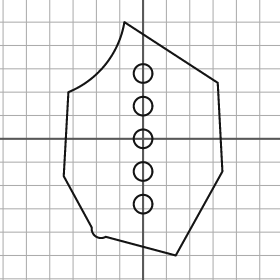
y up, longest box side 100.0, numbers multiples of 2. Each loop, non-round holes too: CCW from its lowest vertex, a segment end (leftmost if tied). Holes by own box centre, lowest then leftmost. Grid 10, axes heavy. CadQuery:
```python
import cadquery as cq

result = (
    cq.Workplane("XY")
    .moveTo(14.0, -50.0)
    .lineTo(34.0, -14.0)
    .lineTo(32.0, 24.0)
    .lineTo(-8.0, 50.0)
    .threePointArc((-16.0, 32.0), (-32.0, 20.0))
    .lineTo(-34.0, -16.0)
    .lineTo(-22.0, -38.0)
    .threePointArc((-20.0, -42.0), (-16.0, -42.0))
    .close()
    .moveTo(0.0, -28.0)
    .circle(4.0)
    .moveTo(0.0, -14.0)
    .circle(4.0)
    .moveTo(0.0, 0.0)
    .circle(4.0)
    .moveTo(0.0, 14.0)
    .circle(4.0)
    .moveTo(0.0, 28.0)
    .circle(4.0)
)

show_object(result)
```